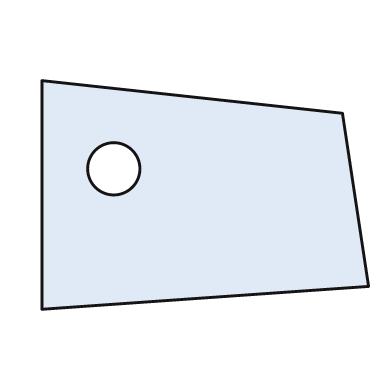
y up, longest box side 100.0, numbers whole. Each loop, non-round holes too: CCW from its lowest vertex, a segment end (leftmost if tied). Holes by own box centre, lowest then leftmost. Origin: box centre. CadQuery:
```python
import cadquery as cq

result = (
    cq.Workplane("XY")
    .moveTo(-50.0, -35.0)
    .lineTo(50.0, -28.0)
    .lineTo(42.0, 25.0)
    .lineTo(-50.0, 35.0)
    .close()
    .moveTo(-28.0, 8.0)
    .circle(8.0)
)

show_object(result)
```